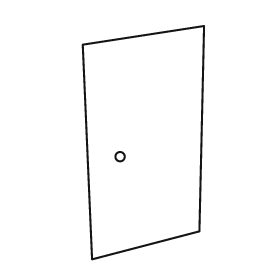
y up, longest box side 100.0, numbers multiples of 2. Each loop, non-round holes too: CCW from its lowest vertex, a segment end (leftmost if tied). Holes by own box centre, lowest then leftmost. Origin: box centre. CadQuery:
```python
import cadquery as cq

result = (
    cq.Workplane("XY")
    .moveTo(-22.0, -50.0)
    .lineTo(24.0, -38.0)
    .lineTo(26.0, 50.0)
    .lineTo(-26.0, 42.0)
    .close()
    .moveTo(-10.0, -6.0)
    .circle(2.0)
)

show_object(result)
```